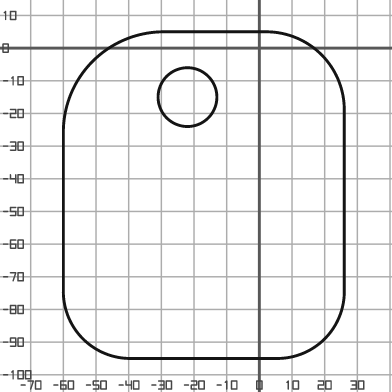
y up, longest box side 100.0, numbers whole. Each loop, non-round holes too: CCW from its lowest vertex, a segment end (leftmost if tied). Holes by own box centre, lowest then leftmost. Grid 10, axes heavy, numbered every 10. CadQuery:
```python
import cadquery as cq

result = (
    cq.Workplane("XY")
    .moveTo(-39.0, -95.0)
    .lineTo(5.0, -95.0)
    .threePointArc((20.0, -89.0), (26.0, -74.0))
    .lineTo(26.0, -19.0)
    .threePointArc((19.0, -2.0), (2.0, 5.0))
    .lineTo(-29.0, 5.0)
    .threePointArc((-51.0, -4.0), (-60.0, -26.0))
    .lineTo(-60.0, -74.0)
    .threePointArc((-54.0, -89.0), (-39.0, -95.0))
    .close()
    .moveTo(-22.0, -15.0)
    .circle(9.0)
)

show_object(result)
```